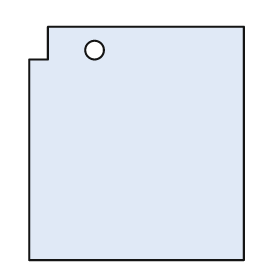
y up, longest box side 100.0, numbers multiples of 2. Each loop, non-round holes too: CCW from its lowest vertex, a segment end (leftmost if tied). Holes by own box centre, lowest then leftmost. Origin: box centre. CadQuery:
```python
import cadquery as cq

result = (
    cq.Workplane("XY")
    .moveTo(-46.0, -50.0)
    .lineTo(46.0, -50.0)
    .lineTo(46.0, 50.0)
    .lineTo(-38.0, 50.0)
    .lineTo(-38.0, 36.0)
    .lineTo(-46.0, 36.0)
    .close()
    .moveTo(-18.0, 40.0)
    .circle(4.0)
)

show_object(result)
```